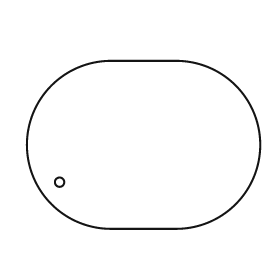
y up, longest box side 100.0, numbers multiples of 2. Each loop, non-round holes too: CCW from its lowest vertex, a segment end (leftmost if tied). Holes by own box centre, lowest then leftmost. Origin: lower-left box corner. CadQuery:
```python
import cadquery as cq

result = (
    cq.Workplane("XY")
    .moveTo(36.0, 0.0)
    .lineTo(64.0, 0.0)
    .threePointArc((100.0, 36.0), (64.0, 72.0))
    .lineTo(36.0, 72.0)
    .threePointArc((0.0, 36.0), (36.0, 0.0))
    .close()
    .moveTo(14.0, 20.0)
    .circle(2.0)
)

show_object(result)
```